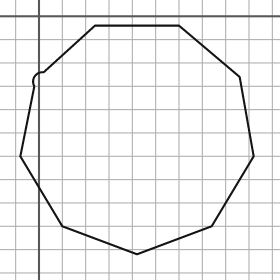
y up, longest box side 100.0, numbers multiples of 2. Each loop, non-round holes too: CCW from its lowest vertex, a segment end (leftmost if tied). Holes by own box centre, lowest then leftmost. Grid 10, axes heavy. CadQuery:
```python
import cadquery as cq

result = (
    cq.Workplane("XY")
    .moveTo(42.0, -102.0)
    .lineTo(74.0, -90.0)
    .lineTo(92.0, -60.0)
    .lineTo(86.0, -26.0)
    .lineTo(60.0, -4.0)
    .lineTo(24.0, -4.0)
    .lineTo(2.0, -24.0)
    .threePointArc((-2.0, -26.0), (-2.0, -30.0))
    .lineTo(-8.0, -60.0)
    .lineTo(10.0, -90.0)
    .close()
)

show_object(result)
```